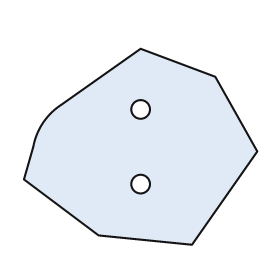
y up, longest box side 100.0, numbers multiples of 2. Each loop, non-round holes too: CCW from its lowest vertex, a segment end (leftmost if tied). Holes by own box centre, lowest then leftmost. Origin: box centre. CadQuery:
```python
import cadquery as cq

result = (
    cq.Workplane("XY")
    .moveTo(22.0, -42.0)
    .lineTo(50.0, -2.0)
    .lineTo(32.0, 30.0)
    .lineTo(0.0, 42.0)
    .lineTo(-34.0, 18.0)
    .threePointArc((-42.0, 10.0), (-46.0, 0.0))
    .lineTo(-50.0, -14.0)
    .lineTo(-18.0, -38.0)
    .close()
    .moveTo(0.0, -16.0)
    .circle(4.0)
    .moveTo(0.0, 16.0)
    .circle(4.0)
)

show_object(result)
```